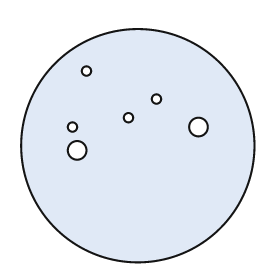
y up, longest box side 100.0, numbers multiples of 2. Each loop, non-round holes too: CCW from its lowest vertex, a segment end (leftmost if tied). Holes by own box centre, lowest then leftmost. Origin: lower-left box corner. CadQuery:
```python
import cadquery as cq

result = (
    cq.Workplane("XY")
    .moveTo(50.0, 50.0)
    .circle(50.0)
    .moveTo(24.0, 48.0)
    .circle(4.0)
    .moveTo(22.0, 58.0)
    .circle(2.0)
    .moveTo(76.0, 58.0)
    .circle(4.0)
    .moveTo(46.0, 62.0)
    .circle(2.0)
    .moveTo(58.0, 70.0)
    .circle(2.0)
    .moveTo(28.0, 82.0)
    .circle(2.0)
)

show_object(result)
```